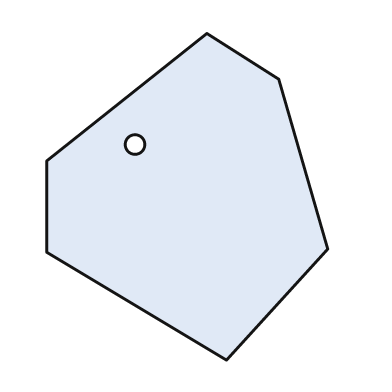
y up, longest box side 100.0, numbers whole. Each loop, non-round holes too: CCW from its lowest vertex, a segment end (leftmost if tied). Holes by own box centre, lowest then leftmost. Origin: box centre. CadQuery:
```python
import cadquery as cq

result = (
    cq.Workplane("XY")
    .moveTo(12.0, -50.0)
    .lineTo(43.0, -16.0)
    .lineTo(28.0, 36.0)
    .lineTo(6.0, 50.0)
    .lineTo(-43.0, 11.0)
    .lineTo(-43.0, -17.0)
    .close()
    .moveTo(-16.0, 16.0)
    .circle(3.0)
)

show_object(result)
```